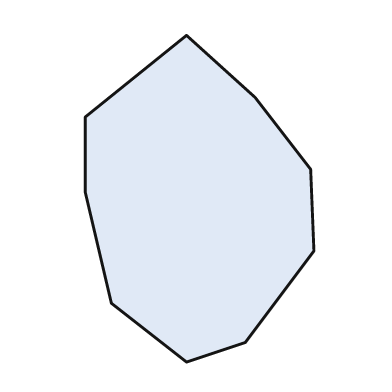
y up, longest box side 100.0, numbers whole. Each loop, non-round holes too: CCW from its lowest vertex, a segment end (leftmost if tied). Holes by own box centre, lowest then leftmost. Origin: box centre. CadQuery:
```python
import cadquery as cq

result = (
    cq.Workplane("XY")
    .moveTo(-4.0, -50.0)
    .lineTo(14.0, -44.0)
    .lineTo(35.0, -16.0)
    .lineTo(34.0, 9.0)
    .lineTo(17.0, 31.0)
    .lineTo(-4.0, 50.0)
    .lineTo(-35.0, 25.0)
    .lineTo(-35.0, 2.0)
    .lineTo(-27.0, -32.0)
    .close()
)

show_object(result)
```